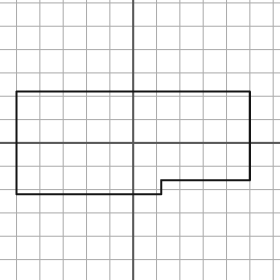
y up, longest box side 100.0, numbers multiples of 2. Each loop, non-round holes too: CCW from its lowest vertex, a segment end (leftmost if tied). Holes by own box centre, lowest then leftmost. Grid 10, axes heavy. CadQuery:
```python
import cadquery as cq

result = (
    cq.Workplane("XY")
    .moveTo(-50.0, -22.0)
    .lineTo(12.0, -22.0)
    .lineTo(12.0, -16.0)
    .lineTo(50.0, -16.0)
    .lineTo(50.0, 22.0)
    .lineTo(-50.0, 22.0)
    .close()
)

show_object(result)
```